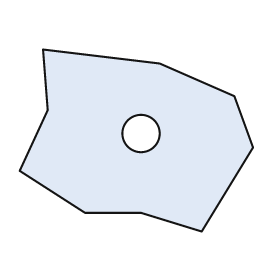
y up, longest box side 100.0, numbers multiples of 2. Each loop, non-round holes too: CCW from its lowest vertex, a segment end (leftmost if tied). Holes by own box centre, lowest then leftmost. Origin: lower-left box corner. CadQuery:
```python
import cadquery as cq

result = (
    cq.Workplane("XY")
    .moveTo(78.0, 0.0)
    .lineTo(100.0, 36.0)
    .lineTo(92.0, 58.0)
    .lineTo(60.0, 72.0)
    .lineTo(10.0, 78.0)
    .lineTo(12.0, 52.0)
    .lineTo(0.0, 26.0)
    .lineTo(28.0, 8.0)
    .lineTo(52.0, 8.0)
    .close()
    .moveTo(52.0, 42.0)
    .circle(8.0)
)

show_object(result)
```